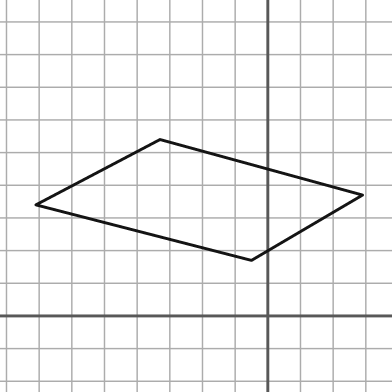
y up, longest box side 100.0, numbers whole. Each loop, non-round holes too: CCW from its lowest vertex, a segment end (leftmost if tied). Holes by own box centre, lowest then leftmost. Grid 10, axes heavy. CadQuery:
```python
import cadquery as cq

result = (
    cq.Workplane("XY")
    .moveTo(-5.0, 17.0)
    .lineTo(29.0, 37.0)
    .lineTo(-33.0, 54.0)
    .lineTo(-71.0, 34.0)
    .close()
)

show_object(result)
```